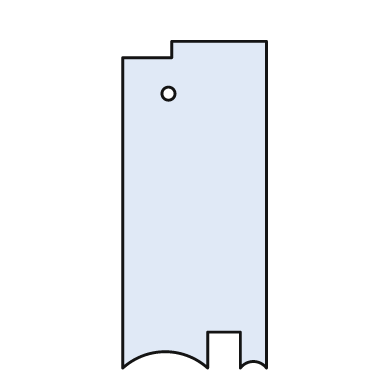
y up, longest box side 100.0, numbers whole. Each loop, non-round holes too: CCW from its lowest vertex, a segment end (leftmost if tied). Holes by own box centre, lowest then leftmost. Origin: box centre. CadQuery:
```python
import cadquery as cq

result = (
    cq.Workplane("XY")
    .moveTo(-22.0, -50.0)
    .threePointArc((-9.0, -45.0), (4.0, -50.0))
    .lineTo(4.0, -39.0)
    .lineTo(14.0, -39.0)
    .lineTo(14.0, -50.0)
    .threePointArc((18.0, -48.0), (22.0, -50.0))
    .lineTo(22.0, 50.0)
    .lineTo(-7.0, 50.0)
    .lineTo(-7.0, 45.0)
    .lineTo(-22.0, 45.0)
    .close()
    .moveTo(-8.0, 34.0)
    .circle(2.0)
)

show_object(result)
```